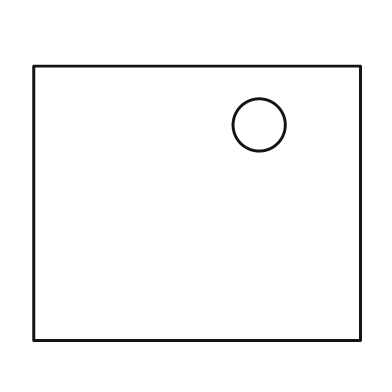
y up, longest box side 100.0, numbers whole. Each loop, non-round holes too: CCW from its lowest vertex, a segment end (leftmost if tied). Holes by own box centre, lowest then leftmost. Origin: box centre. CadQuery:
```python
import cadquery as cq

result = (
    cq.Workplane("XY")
    .moveTo(-50.0, -42.0)
    .lineTo(50.0, -42.0)
    .lineTo(50.0, 42.0)
    .lineTo(-50.0, 42.0)
    .close()
    .moveTo(19.0, 24.0)
    .circle(8.0)
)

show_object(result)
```